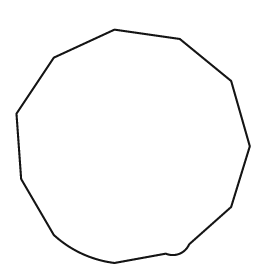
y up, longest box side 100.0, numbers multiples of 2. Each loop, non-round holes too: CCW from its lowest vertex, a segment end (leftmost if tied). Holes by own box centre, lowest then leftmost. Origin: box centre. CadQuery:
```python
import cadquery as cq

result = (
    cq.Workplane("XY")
    .moveTo(-8.0, -50.0)
    .lineTo(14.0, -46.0)
    .threePointArc((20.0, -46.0), (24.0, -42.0))
    .lineTo(42.0, -26.0)
    .lineTo(50.0, 0.0)
    .lineTo(42.0, 28.0)
    .lineTo(20.0, 46.0)
    .lineTo(-8.0, 50.0)
    .lineTo(-34.0, 38.0)
    .lineTo(-50.0, 14.0)
    .lineTo(-48.0, -14.0)
    .lineTo(-34.0, -38.0)
    .threePointArc((-22.0, -46.0), (-8.0, -50.0))
    .close()
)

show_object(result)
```